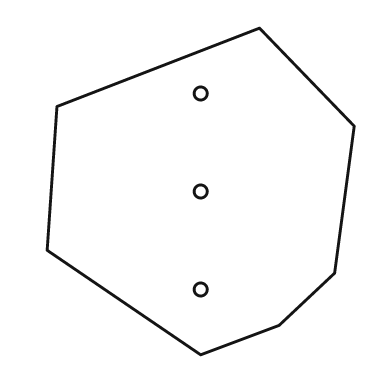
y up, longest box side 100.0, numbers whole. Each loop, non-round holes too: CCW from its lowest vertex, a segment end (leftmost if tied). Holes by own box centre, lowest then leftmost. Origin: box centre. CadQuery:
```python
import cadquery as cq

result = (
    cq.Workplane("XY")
    .moveTo(0.0, -50.0)
    .lineTo(24.0, -41.0)
    .lineTo(41.0, -25.0)
    .lineTo(47.0, 20.0)
    .lineTo(18.0, 50.0)
    .lineTo(-44.0, 26.0)
    .lineTo(-47.0, -18.0)
    .close()
    .moveTo(0.0, -30.0)
    .circle(2.0)
    .moveTo(0.0, 0.0)
    .circle(2.0)
    .moveTo(0.0, 30.0)
    .circle(2.0)
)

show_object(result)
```